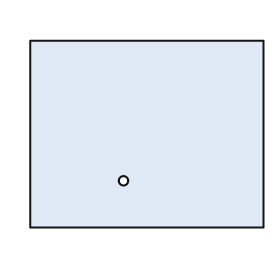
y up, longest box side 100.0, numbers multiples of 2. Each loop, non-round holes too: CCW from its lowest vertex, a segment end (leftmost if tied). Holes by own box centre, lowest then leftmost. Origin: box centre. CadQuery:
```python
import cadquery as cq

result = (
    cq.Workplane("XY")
    .moveTo(-50.0, -40.0)
    .lineTo(50.0, -40.0)
    .lineTo(50.0, 40.0)
    .lineTo(-50.0, 40.0)
    .close()
    .moveTo(-10.0, -20.0)
    .circle(2.0)
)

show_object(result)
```